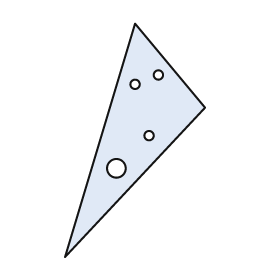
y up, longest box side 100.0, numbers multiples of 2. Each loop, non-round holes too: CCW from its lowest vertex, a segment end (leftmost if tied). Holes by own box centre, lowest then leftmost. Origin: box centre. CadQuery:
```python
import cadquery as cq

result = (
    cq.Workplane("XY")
    .moveTo(-30.0, -50.0)
    .lineTo(30.0, 14.0)
    .lineTo(0.0, 50.0)
    .close()
    .moveTo(-8.0, -12.0)
    .circle(4.0)
    .moveTo(6.0, 2.0)
    .circle(2.0)
    .moveTo(0.0, 24.0)
    .circle(2.0)
    .moveTo(10.0, 28.0)
    .circle(2.0)
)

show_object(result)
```